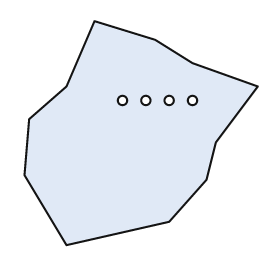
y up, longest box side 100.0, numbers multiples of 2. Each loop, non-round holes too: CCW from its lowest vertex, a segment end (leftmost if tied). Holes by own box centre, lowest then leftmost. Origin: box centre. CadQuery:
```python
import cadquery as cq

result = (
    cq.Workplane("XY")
    .moveTo(-32.0, -48.0)
    .lineTo(12.0, -38.0)
    .lineTo(28.0, -20.0)
    .lineTo(32.0, -4.0)
    .lineTo(50.0, 20.0)
    .lineTo(22.0, 30.0)
    .lineTo(6.0, 40.0)
    .lineTo(-20.0, 48.0)
    .lineTo(-32.0, 20.0)
    .lineTo(-48.0, 6.0)
    .lineTo(-50.0, -18.0)
    .close()
    .moveTo(-8.0, 14.0)
    .circle(2.0)
    .moveTo(2.0, 14.0)
    .circle(2.0)
    .moveTo(12.0, 14.0)
    .circle(2.0)
    .moveTo(22.0, 14.0)
    .circle(2.0)
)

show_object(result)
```